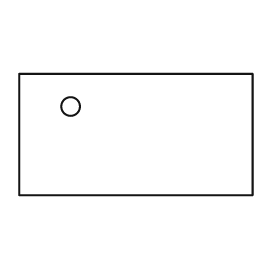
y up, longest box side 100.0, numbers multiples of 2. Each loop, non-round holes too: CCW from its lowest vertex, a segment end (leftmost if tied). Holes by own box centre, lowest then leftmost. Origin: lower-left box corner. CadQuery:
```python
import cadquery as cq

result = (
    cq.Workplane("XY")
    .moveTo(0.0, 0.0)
    .lineTo(100.0, 0.0)
    .lineTo(100.0, 52.0)
    .lineTo(0.0, 52.0)
    .close()
    .moveTo(22.0, 38.0)
    .circle(4.0)
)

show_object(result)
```